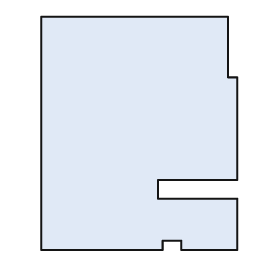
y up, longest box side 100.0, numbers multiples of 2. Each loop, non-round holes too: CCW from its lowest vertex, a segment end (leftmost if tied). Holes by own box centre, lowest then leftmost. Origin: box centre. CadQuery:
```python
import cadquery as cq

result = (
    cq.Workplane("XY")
    .moveTo(-42.0, -50.0)
    .lineTo(10.0, -50.0)
    .lineTo(10.0, -46.0)
    .lineTo(18.0, -46.0)
    .lineTo(18.0, -50.0)
    .lineTo(42.0, -50.0)
    .lineTo(42.0, -28.0)
    .lineTo(8.0, -28.0)
    .lineTo(8.0, -20.0)
    .lineTo(42.0, -20.0)
    .lineTo(42.0, 24.0)
    .lineTo(38.0, 24.0)
    .lineTo(38.0, 50.0)
    .lineTo(-42.0, 50.0)
    .close()
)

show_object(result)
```